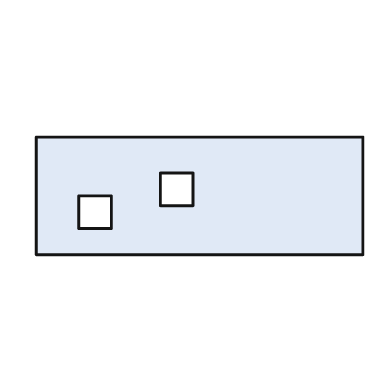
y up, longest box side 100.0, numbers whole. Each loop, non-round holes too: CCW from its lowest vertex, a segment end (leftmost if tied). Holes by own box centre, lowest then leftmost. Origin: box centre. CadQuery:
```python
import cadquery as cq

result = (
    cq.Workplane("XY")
    .moveTo(-50.0, -18.0)
    .lineTo(50.0, -18.0)
    .lineTo(50.0, 18.0)
    .lineTo(-50.0, 18.0)
    .close()
    .moveTo(-37.0, -10.0)
    .lineTo(-27.0, -10.0)
    .lineTo(-27.0, 0.0)
    .lineTo(-37.0, 0.0)
    .close()
    .moveTo(-12.0, -3.0)
    .lineTo(-2.0, -3.0)
    .lineTo(-2.0, 7.0)
    .lineTo(-12.0, 7.0)
    .close()
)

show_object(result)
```